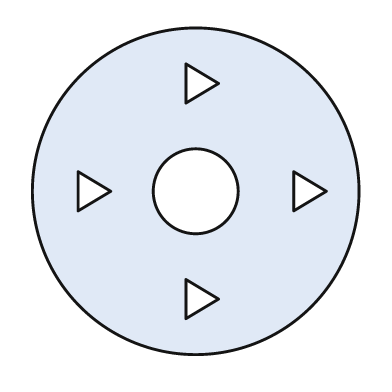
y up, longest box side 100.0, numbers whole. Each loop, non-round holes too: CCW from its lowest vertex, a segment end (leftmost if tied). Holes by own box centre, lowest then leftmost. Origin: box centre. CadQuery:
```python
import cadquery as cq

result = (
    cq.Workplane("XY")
    .moveTo(0.0, 0.0)
    .circle(50.0)
    .moveTo(-3.0, -39.0)
    .lineTo(7.0, -33.0)
    .lineTo(-3.0, -27.0)
    .close()
    .moveTo(-36.0, -6.0)
    .lineTo(-26.0, 0.0)
    .lineTo(-36.0, 6.0)
    .close()
    .moveTo(0.0, 0.0)
    .circle(13.0)
    .moveTo(30.0, -6.0)
    .lineTo(40.0, 0.0)
    .lineTo(30.0, 6.0)
    .close()
    .moveTo(-3.0, 27.0)
    .lineTo(7.0, 33.0)
    .lineTo(-3.0, 39.0)
    .close()
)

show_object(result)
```